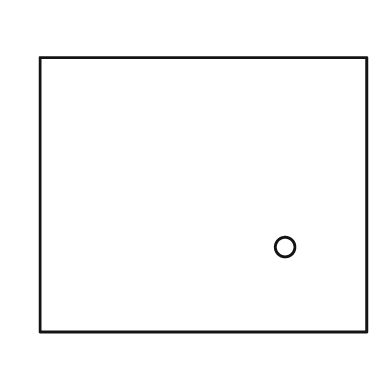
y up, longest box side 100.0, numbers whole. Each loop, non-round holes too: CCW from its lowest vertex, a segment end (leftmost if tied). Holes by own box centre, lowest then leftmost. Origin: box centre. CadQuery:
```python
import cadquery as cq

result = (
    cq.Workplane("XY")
    .moveTo(-50.0, -42.0)
    .lineTo(50.0, -42.0)
    .lineTo(50.0, 42.0)
    .lineTo(-50.0, 42.0)
    .close()
    .moveTo(25.0, -16.0)
    .circle(3.0)
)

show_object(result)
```